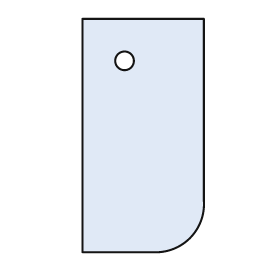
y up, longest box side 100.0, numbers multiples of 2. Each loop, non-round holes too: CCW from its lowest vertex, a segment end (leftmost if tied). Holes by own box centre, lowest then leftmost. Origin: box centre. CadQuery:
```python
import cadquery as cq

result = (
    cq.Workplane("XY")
    .moveTo(-26.0, -50.0)
    .lineTo(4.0, -50.0)
    .threePointArc((20.0, -44.0), (26.0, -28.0))
    .lineTo(26.0, 50.0)
    .lineTo(-26.0, 50.0)
    .close()
    .moveTo(-8.0, 32.0)
    .circle(4.0)
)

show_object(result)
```